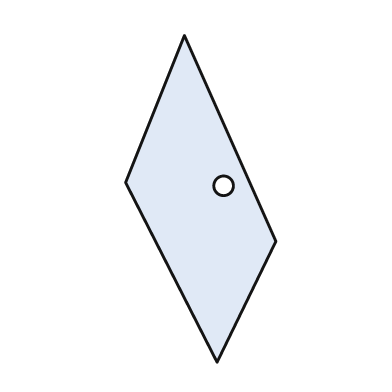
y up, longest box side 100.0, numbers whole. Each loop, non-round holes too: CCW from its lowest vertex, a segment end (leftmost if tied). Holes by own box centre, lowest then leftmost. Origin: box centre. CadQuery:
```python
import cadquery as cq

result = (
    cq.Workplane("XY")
    .moveTo(5.0, -50.0)
    .lineTo(23.0, -13.0)
    .lineTo(-5.0, 50.0)
    .lineTo(-23.0, 5.0)
    .close()
    .moveTo(7.0, 4.0)
    .circle(3.0)
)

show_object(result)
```